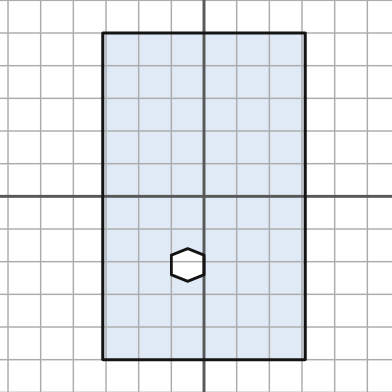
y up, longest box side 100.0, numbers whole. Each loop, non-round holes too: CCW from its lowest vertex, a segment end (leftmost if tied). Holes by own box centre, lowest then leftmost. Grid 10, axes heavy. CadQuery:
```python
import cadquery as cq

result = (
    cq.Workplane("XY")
    .moveTo(-31.0, -50.0)
    .lineTo(31.0, -50.0)
    .lineTo(31.0, 50.0)
    .lineTo(-31.0, 50.0)
    .close()
    .moveTo(-5.0, -26.0)
    .lineTo(0.0, -24.0)
    .lineTo(0.0, -18.0)
    .lineTo(-5.0, -16.0)
    .lineTo(-10.0, -18.0)
    .lineTo(-10.0, -24.0)
    .close()
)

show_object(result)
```